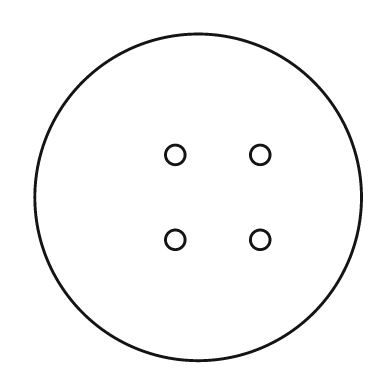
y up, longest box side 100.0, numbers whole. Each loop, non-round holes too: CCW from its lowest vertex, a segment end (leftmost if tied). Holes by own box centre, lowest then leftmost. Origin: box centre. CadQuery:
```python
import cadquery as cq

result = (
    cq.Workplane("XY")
    .moveTo(0.0, 0.0)
    .circle(50.0)
    .moveTo(-7.0, -13.0)
    .circle(3.0)
    .moveTo(19.0, -13.0)
    .circle(3.0)
    .moveTo(-7.0, 13.0)
    .circle(3.0)
    .moveTo(19.0, 13.0)
    .circle(3.0)
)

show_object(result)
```